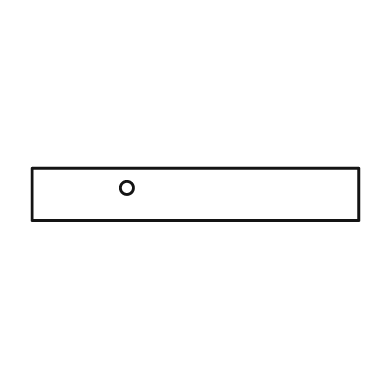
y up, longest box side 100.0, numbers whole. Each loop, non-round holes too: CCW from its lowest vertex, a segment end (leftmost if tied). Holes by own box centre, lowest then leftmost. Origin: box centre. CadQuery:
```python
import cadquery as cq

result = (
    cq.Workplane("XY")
    .moveTo(-50.0, -8.0)
    .lineTo(50.0, -8.0)
    .lineTo(50.0, 8.0)
    .lineTo(-50.0, 8.0)
    .close()
    .moveTo(-21.0, 2.0)
    .circle(2.0)
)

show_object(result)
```